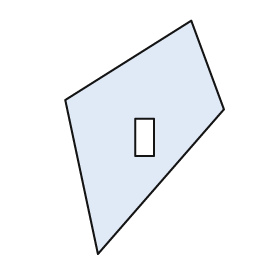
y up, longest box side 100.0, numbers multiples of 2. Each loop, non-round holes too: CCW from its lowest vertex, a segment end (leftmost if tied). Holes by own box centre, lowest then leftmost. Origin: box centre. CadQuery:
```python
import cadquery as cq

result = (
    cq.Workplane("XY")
    .moveTo(-20.0, -50.0)
    .lineTo(34.0, 12.0)
    .lineTo(20.0, 50.0)
    .lineTo(-34.0, 16.0)
    .close()
    .moveTo(-4.0, -8.0)
    .lineTo(4.0, -8.0)
    .lineTo(4.0, 8.0)
    .lineTo(-4.0, 8.0)
    .close()
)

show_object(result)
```